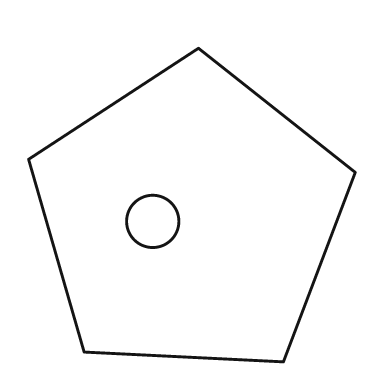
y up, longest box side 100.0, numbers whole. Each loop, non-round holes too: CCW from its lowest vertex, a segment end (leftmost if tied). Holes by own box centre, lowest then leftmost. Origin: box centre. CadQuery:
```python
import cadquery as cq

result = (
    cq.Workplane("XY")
    .moveTo(28.0, -48.0)
    .lineTo(50.0, 10.0)
    .lineTo(2.0, 48.0)
    .lineTo(-50.0, 14.0)
    .lineTo(-33.0, -45.0)
    .close()
    .moveTo(-12.0, -5.0)
    .circle(8.0)
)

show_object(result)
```